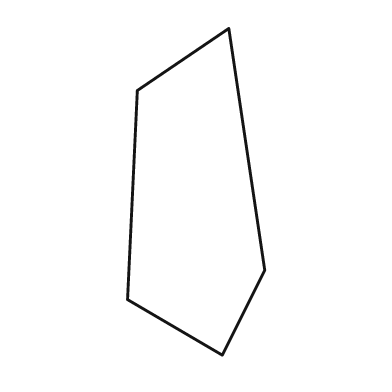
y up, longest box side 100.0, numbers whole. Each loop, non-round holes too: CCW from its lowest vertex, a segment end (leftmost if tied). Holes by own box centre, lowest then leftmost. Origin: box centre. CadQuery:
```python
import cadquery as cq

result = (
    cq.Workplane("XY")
    .moveTo(8.0, -50.0)
    .lineTo(21.0, -24.0)
    .lineTo(10.0, 50.0)
    .lineTo(-18.0, 31.0)
    .lineTo(-21.0, -33.0)
    .close()
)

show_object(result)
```